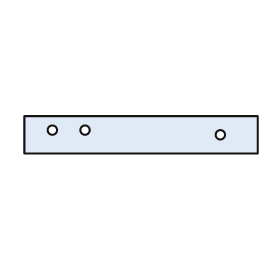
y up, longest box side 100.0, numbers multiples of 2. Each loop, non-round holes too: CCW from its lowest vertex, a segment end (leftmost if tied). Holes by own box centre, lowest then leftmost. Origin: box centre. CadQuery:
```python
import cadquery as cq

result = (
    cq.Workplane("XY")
    .moveTo(-50.0, -8.0)
    .lineTo(50.0, -8.0)
    .lineTo(50.0, 8.0)
    .lineTo(-50.0, 8.0)
    .close()
    .moveTo(34.0, 0.0)
    .circle(2.0)
    .moveTo(-38.0, 2.0)
    .circle(2.0)
    .moveTo(-24.0, 2.0)
    .circle(2.0)
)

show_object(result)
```